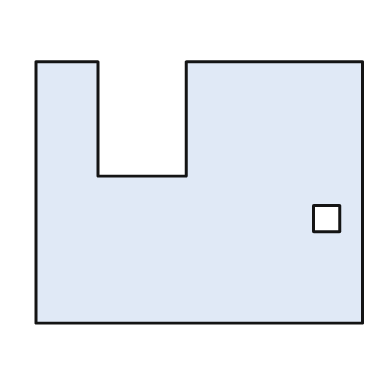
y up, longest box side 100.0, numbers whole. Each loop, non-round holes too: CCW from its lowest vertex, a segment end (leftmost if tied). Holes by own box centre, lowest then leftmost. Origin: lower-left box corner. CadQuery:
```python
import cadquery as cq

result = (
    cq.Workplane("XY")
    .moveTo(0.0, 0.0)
    .lineTo(100.0, 0.0)
    .lineTo(100.0, 80.0)
    .lineTo(46.0, 80.0)
    .lineTo(46.0, 45.0)
    .lineTo(19.0, 45.0)
    .lineTo(19.0, 80.0)
    .lineTo(0.0, 80.0)
    .close()
    .moveTo(85.0, 28.0)
    .lineTo(93.0, 28.0)
    .lineTo(93.0, 36.0)
    .lineTo(85.0, 36.0)
    .close()
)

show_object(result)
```